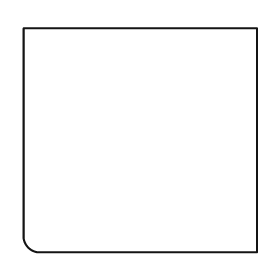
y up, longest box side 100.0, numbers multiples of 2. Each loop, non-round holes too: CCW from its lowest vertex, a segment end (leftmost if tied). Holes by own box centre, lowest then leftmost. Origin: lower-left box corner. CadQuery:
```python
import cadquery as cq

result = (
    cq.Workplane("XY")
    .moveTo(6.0, 0.0)
    .lineTo(100.0, 0.0)
    .lineTo(100.0, 96.0)
    .lineTo(0.0, 96.0)
    .lineTo(0.0, 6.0)
    .threePointArc((2.0, 2.0), (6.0, 0.0))
    .close()
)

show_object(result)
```